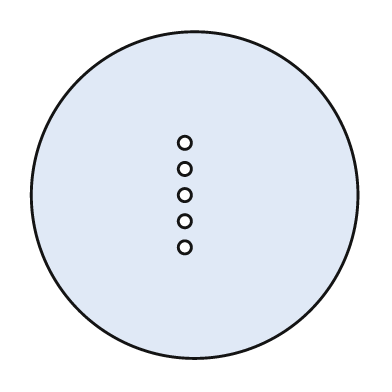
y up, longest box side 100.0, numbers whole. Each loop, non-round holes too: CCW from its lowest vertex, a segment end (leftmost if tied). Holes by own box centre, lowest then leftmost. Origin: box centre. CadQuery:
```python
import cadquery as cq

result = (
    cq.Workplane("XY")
    .moveTo(0.0, 0.0)
    .circle(50.0)
    .moveTo(-3.0, -16.0)
    .circle(2.0)
    .moveTo(-3.0, -8.0)
    .circle(2.0)
    .moveTo(-3.0, 0.0)
    .circle(2.0)
    .moveTo(-3.0, 8.0)
    .circle(2.0)
    .moveTo(-3.0, 16.0)
    .circle(2.0)
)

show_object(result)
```